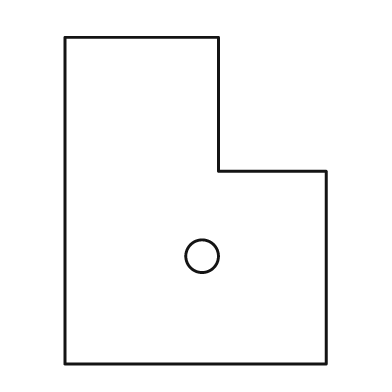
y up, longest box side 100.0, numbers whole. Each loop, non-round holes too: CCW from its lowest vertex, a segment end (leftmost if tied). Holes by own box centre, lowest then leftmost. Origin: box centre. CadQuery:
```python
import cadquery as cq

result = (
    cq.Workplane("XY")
    .moveTo(-40.0, -50.0)
    .lineTo(40.0, -50.0)
    .lineTo(40.0, 9.0)
    .lineTo(7.0, 9.0)
    .lineTo(7.0, 50.0)
    .lineTo(-40.0, 50.0)
    .close()
    .moveTo(2.0, -17.0)
    .circle(5.0)
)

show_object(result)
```